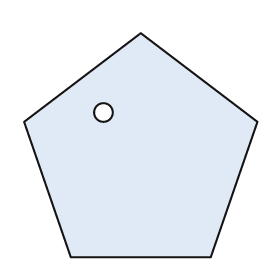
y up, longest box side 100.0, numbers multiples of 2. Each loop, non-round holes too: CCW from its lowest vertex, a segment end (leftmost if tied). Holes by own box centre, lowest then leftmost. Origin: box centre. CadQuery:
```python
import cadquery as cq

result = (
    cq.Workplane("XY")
    .moveTo(-30.0, -48.0)
    .lineTo(30.0, -48.0)
    .lineTo(50.0, 10.0)
    .lineTo(0.0, 48.0)
    .lineTo(-50.0, 10.0)
    .close()
    .moveTo(-16.0, 14.0)
    .circle(4.0)
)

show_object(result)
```